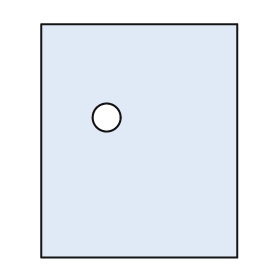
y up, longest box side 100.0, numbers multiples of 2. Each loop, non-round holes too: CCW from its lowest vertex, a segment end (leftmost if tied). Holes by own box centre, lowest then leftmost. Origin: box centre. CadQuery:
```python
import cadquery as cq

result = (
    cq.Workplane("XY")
    .moveTo(-42.0, -50.0)
    .lineTo(42.0, -50.0)
    .lineTo(42.0, 50.0)
    .lineTo(-42.0, 50.0)
    .close()
    .moveTo(-14.0, 10.0)
    .circle(6.0)
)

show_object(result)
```